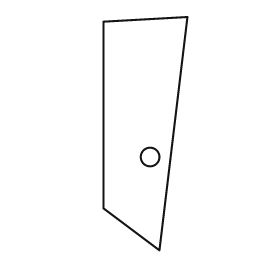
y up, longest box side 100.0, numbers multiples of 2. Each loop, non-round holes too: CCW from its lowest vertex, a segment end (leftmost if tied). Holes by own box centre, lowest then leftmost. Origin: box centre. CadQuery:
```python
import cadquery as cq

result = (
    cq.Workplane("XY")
    .moveTo(6.0, -50.0)
    .lineTo(18.0, 50.0)
    .lineTo(-18.0, 48.0)
    .lineTo(-18.0, -32.0)
    .close()
    .moveTo(2.0, -10.0)
    .circle(4.0)
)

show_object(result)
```